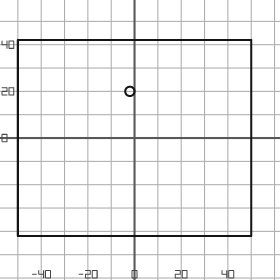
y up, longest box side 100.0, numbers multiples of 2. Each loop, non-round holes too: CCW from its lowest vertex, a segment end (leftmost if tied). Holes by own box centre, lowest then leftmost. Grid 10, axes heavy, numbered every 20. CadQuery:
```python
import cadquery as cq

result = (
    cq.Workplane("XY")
    .moveTo(-50.0, -42.0)
    .lineTo(50.0, -42.0)
    .lineTo(50.0, 42.0)
    .lineTo(-50.0, 42.0)
    .close()
    .moveTo(-2.0, 20.0)
    .circle(2.0)
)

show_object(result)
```